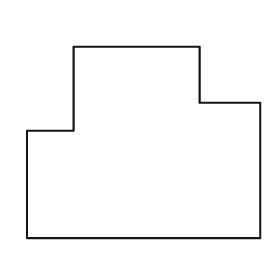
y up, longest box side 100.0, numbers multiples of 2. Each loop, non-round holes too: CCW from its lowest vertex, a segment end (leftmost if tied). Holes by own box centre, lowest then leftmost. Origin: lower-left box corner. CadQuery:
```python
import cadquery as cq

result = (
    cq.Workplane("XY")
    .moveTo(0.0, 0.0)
    .lineTo(100.0, 0.0)
    .lineTo(100.0, 58.0)
    .lineTo(74.0, 58.0)
    .lineTo(74.0, 82.0)
    .lineTo(20.0, 82.0)
    .lineTo(20.0, 46.0)
    .lineTo(0.0, 46.0)
    .close()
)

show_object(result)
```